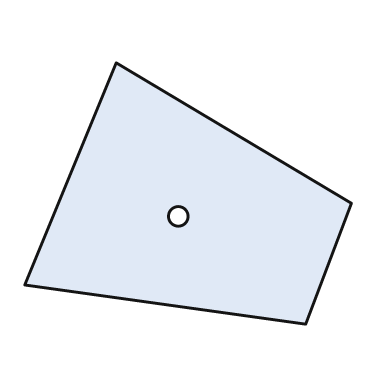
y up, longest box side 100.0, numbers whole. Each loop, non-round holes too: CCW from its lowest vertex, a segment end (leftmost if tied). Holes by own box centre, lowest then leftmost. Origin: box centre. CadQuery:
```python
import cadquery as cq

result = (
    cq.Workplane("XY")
    .moveTo(36.0, -40.0)
    .lineTo(50.0, -3.0)
    .lineTo(-22.0, 40.0)
    .lineTo(-50.0, -28.0)
    .close()
    .moveTo(-3.0, -7.0)
    .circle(3.0)
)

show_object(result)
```